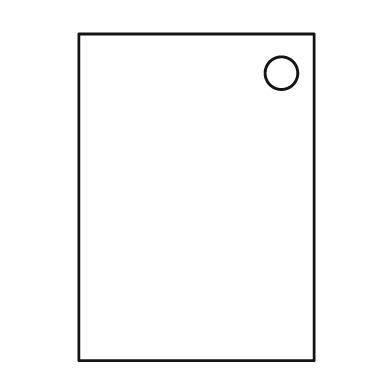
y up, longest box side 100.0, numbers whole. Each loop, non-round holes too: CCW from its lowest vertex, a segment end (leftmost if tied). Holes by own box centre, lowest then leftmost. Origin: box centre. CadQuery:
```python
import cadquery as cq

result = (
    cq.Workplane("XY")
    .moveTo(-36.0, -50.0)
    .lineTo(36.0, -50.0)
    .lineTo(36.0, 50.0)
    .lineTo(-36.0, 50.0)
    .close()
    .moveTo(26.0, 38.0)
    .circle(5.0)
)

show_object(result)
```